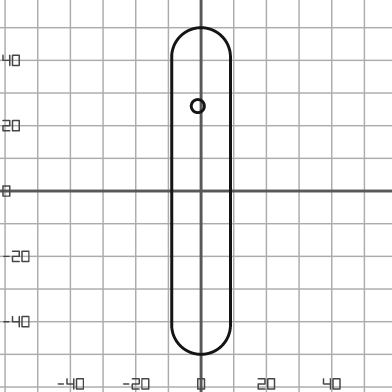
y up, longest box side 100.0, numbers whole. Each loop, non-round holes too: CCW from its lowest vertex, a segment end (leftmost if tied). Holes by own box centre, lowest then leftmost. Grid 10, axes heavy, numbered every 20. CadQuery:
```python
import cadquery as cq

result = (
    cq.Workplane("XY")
    .moveTo(-9.0, -41.0)
    .threePointArc((0.0, -50.0), (9.0, -41.0))
    .lineTo(9.0, 41.0)
    .threePointArc((0.0, 50.0), (-9.0, 41.0))
    .close()
    .moveTo(-1.0, 26.0)
    .circle(2.0)
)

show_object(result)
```